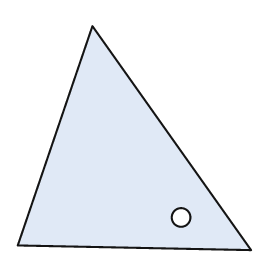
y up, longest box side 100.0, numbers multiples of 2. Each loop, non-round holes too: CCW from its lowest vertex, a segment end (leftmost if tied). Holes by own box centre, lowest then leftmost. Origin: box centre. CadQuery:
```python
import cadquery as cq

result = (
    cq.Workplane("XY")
    .moveTo(50.0, -48.0)
    .lineTo(-18.0, 48.0)
    .lineTo(-50.0, -46.0)
    .close()
    .moveTo(20.0, -34.0)
    .circle(4.0)
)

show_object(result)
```